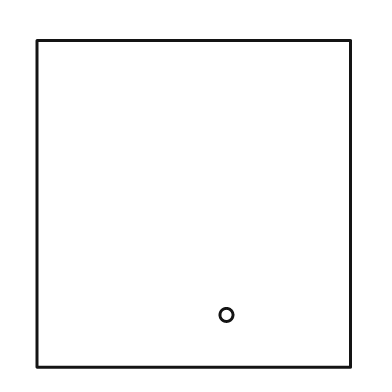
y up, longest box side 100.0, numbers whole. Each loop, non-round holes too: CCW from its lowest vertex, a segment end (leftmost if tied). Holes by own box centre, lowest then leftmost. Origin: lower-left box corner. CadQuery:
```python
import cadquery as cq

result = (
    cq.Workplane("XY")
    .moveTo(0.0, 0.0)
    .lineTo(96.0, 0.0)
    .lineTo(96.0, 100.0)
    .lineTo(0.0, 100.0)
    .close()
    .moveTo(58.0, 16.0)
    .circle(2.0)
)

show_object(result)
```